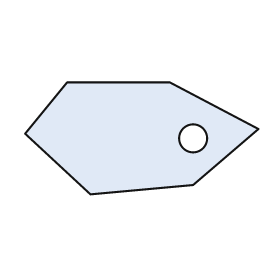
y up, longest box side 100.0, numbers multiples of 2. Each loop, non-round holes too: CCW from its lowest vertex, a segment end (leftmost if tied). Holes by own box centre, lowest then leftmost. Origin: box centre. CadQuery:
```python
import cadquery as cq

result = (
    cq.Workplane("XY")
    .moveTo(-22.0, -24.0)
    .lineTo(22.0, -20.0)
    .lineTo(50.0, 4.0)
    .lineTo(12.0, 24.0)
    .lineTo(-32.0, 24.0)
    .lineTo(-50.0, 2.0)
    .close()
    .moveTo(22.0, 0.0)
    .circle(6.0)
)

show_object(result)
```